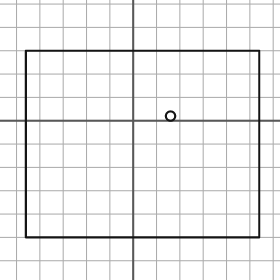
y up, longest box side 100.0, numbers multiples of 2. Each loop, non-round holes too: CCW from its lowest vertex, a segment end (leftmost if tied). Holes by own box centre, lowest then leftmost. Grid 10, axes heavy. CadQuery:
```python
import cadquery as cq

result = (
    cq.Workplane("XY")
    .moveTo(-46.0, -50.0)
    .lineTo(54.0, -50.0)
    .lineTo(54.0, 30.0)
    .lineTo(-46.0, 30.0)
    .close()
    .moveTo(16.0, 2.0)
    .circle(2.0)
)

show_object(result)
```